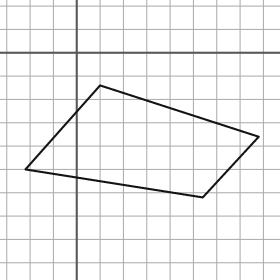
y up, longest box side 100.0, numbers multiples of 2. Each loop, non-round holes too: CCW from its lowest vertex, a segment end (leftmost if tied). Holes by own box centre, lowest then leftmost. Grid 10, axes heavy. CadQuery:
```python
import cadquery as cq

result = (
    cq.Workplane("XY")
    .moveTo(54.0, -62.0)
    .lineTo(78.0, -36.0)
    .lineTo(10.0, -14.0)
    .lineTo(-22.0, -50.0)
    .close()
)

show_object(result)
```